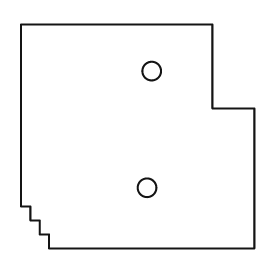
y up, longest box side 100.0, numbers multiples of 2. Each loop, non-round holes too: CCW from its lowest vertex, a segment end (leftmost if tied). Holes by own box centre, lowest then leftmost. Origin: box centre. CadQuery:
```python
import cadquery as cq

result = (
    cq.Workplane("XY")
    .moveTo(-38.0, -48.0)
    .lineTo(50.0, -48.0)
    .lineTo(50.0, 12.0)
    .lineTo(32.0, 12.0)
    .lineTo(32.0, 48.0)
    .lineTo(-50.0, 48.0)
    .lineTo(-50.0, -30.0)
    .lineTo(-46.0, -30.0)
    .lineTo(-46.0, -36.0)
    .lineTo(-42.0, -36.0)
    .lineTo(-42.0, -42.0)
    .lineTo(-38.0, -42.0)
    .close()
    .moveTo(4.0, -22.0)
    .circle(4.0)
    .moveTo(6.0, 28.0)
    .circle(4.0)
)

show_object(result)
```